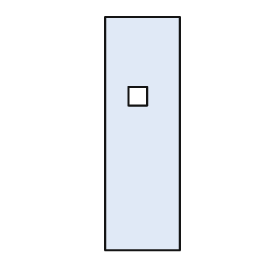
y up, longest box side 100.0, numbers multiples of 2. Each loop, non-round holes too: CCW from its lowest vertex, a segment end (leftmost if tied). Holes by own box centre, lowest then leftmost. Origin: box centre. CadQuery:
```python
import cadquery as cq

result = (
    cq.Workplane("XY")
    .moveTo(-16.0, -50.0)
    .lineTo(16.0, -50.0)
    .lineTo(16.0, 50.0)
    .lineTo(-16.0, 50.0)
    .close()
    .moveTo(-6.0, 12.0)
    .lineTo(2.0, 12.0)
    .lineTo(2.0, 20.0)
    .lineTo(-6.0, 20.0)
    .close()
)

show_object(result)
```